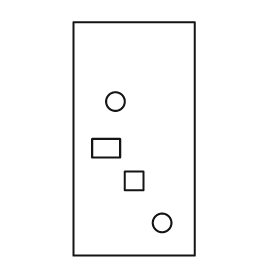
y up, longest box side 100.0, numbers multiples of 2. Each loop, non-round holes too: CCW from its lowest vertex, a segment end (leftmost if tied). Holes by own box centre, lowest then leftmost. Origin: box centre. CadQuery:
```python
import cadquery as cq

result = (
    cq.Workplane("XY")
    .moveTo(-26.0, -50.0)
    .lineTo(26.0, -50.0)
    .lineTo(26.0, 50.0)
    .lineTo(-26.0, 50.0)
    .close()
    .moveTo(12.0, -36.0)
    .circle(4.0)
    .moveTo(-4.0, -22.0)
    .lineTo(4.0, -22.0)
    .lineTo(4.0, -14.0)
    .lineTo(-4.0, -14.0)
    .close()
    .moveTo(-18.0, -8.0)
    .lineTo(-6.0, -8.0)
    .lineTo(-6.0, 0.0)
    .lineTo(-18.0, 0.0)
    .close()
    .moveTo(-8.0, 16.0)
    .circle(4.0)
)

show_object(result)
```